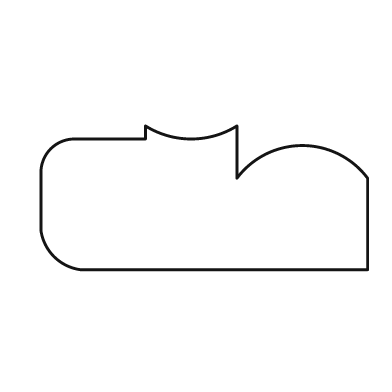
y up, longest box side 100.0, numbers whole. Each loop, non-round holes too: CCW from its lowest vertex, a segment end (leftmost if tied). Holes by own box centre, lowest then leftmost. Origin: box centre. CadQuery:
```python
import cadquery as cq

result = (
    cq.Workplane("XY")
    .moveTo(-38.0, -22.0)
    .lineTo(50.0, -22.0)
    .lineTo(50.0, 6.0)
    .threePointArc((30.0, 16.0), (10.0, 6.0))
    .lineTo(10.0, 22.0)
    .threePointArc((-4.0, 18.0), (-18.0, 22.0))
    .lineTo(-18.0, 18.0)
    .lineTo(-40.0, 18.0)
    .threePointArc((-47.0, 15.0), (-50.0, 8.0))
    .lineTo(-50.0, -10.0)
    .threePointArc((-46.0, -18.0), (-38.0, -22.0))
    .close()
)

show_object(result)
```